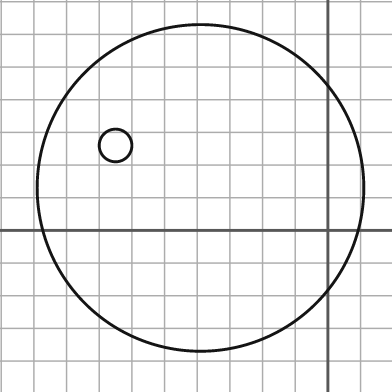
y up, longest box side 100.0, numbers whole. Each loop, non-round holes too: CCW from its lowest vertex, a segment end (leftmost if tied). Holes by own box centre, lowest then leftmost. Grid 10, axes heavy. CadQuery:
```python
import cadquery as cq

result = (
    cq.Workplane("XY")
    .moveTo(-39.0, 13.0)
    .circle(50.0)
    .moveTo(-65.0, 26.0)
    .circle(5.0)
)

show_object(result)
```